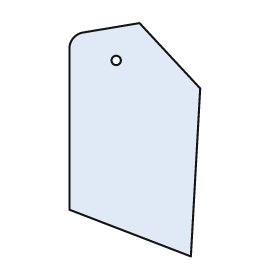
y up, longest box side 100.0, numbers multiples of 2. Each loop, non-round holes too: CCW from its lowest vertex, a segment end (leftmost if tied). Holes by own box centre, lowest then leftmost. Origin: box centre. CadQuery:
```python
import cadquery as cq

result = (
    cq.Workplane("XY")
    .moveTo(24.0, -50.0)
    .lineTo(28.0, 22.0)
    .lineTo(2.0, 50.0)
    .lineTo(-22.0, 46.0)
    .threePointArc((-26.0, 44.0), (-28.0, 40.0))
    .lineTo(-28.0, -30.0)
    .close()
    .moveTo(-8.0, 34.0)
    .circle(2.0)
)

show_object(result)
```